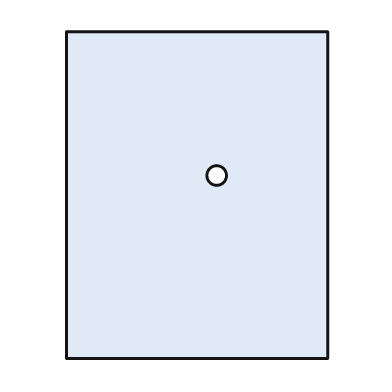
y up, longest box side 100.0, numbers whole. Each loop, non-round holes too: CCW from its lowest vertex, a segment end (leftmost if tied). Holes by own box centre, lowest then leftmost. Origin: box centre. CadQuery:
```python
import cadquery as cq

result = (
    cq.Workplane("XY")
    .moveTo(-40.0, -50.0)
    .lineTo(40.0, -50.0)
    .lineTo(40.0, 50.0)
    .lineTo(-40.0, 50.0)
    .close()
    .moveTo(6.0, 6.0)
    .circle(3.0)
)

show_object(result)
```